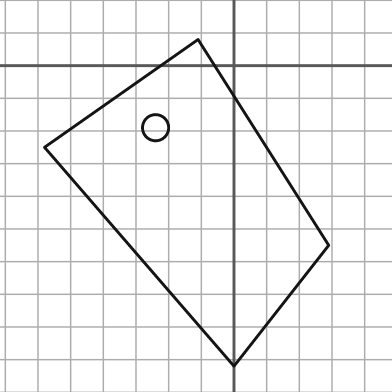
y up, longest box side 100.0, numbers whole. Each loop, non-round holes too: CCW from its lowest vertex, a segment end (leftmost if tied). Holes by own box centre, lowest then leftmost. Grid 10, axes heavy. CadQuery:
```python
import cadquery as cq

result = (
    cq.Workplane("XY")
    .moveTo(0.0, -92.0)
    .lineTo(29.0, -55.0)
    .lineTo(-11.0, 8.0)
    .lineTo(-58.0, -25.0)
    .close()
    .moveTo(-24.0, -19.0)
    .circle(4.0)
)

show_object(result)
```